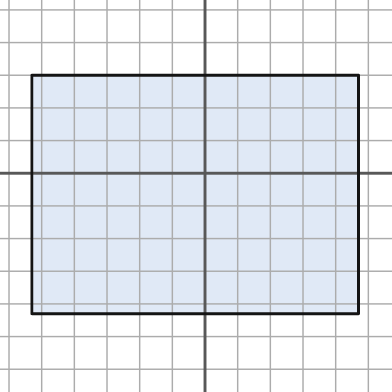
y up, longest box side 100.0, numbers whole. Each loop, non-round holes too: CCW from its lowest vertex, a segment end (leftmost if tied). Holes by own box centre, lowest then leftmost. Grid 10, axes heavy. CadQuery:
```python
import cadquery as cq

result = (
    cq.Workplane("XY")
    .moveTo(-53.0, -43.0)
    .lineTo(47.0, -43.0)
    .lineTo(47.0, 30.0)
    .lineTo(-53.0, 30.0)
    .close()
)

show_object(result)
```